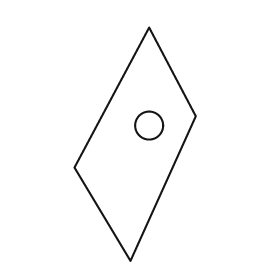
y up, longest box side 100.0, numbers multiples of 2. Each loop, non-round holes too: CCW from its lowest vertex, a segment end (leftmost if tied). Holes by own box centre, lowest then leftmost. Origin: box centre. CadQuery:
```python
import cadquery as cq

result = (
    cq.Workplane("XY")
    .moveTo(-2.0, -50.0)
    .lineTo(26.0, 12.0)
    .lineTo(6.0, 50.0)
    .lineTo(-26.0, -10.0)
    .close()
    .moveTo(6.0, 8.0)
    .circle(6.0)
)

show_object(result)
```